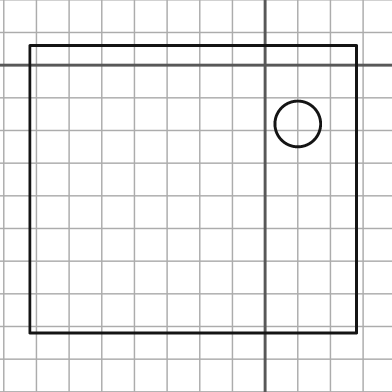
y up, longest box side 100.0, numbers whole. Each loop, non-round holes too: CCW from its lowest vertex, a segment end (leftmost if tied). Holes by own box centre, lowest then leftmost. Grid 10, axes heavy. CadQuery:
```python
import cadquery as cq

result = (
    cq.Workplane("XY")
    .moveTo(-72.0, -82.0)
    .lineTo(28.0, -82.0)
    .lineTo(28.0, 6.0)
    .lineTo(-72.0, 6.0)
    .close()
    .moveTo(10.0, -18.0)
    .circle(7.0)
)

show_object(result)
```